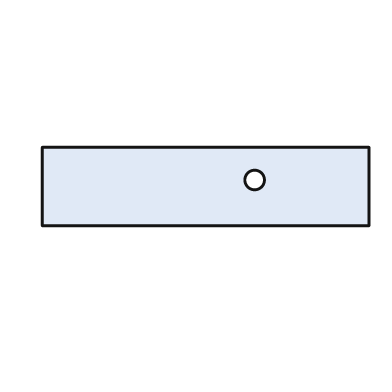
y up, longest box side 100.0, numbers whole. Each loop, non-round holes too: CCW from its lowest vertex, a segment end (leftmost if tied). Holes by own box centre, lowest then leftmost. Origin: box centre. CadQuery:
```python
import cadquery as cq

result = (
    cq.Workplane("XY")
    .moveTo(-50.0, -12.0)
    .lineTo(50.0, -12.0)
    .lineTo(50.0, 12.0)
    .lineTo(-50.0, 12.0)
    .close()
    .moveTo(15.0, 2.0)
    .circle(3.0)
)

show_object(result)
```